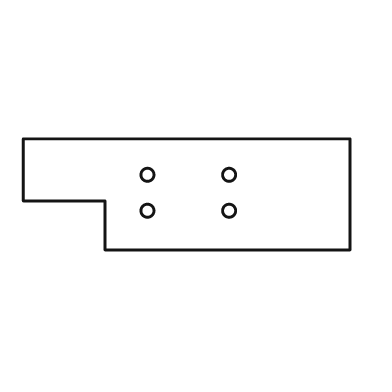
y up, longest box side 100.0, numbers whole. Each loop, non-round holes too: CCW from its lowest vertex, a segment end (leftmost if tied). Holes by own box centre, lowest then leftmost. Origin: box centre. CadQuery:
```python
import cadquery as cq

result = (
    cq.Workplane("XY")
    .moveTo(-25.0, -17.0)
    .lineTo(50.0, -17.0)
    .lineTo(50.0, 17.0)
    .lineTo(-50.0, 17.0)
    .lineTo(-50.0, -2.0)
    .lineTo(-25.0, -2.0)
    .close()
    .moveTo(-12.0, -5.0)
    .circle(2.0)
    .moveTo(13.0, -5.0)
    .circle(2.0)
    .moveTo(-12.0, 6.0)
    .circle(2.0)
    .moveTo(13.0, 6.0)
    .circle(2.0)
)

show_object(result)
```